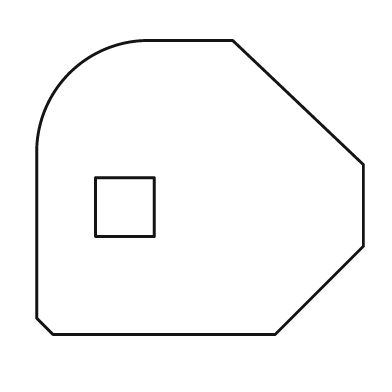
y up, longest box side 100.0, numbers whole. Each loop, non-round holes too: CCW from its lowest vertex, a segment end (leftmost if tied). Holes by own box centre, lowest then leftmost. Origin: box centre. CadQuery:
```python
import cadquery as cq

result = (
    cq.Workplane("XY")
    .moveTo(-45.0, -45.0)
    .lineTo(23.0, -45.0)
    .lineTo(50.0, -18.0)
    .lineTo(50.0, 7.0)
    .lineTo(10.0, 45.0)
    .lineTo(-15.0, 45.0)
    .threePointArc((-40.0, 35.0), (-50.0, 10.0))
    .lineTo(-50.0, -40.0)
    .close()
    .moveTo(-32.0, -15.0)
    .lineTo(-14.0, -15.0)
    .lineTo(-14.0, 3.0)
    .lineTo(-32.0, 3.0)
    .close()
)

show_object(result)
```